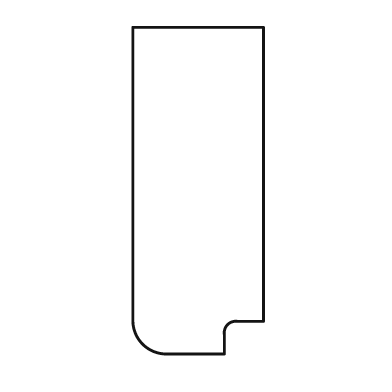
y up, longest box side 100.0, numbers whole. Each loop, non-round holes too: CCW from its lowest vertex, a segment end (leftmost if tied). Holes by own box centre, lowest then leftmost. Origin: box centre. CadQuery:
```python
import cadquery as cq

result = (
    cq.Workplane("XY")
    .moveTo(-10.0, -50.0)
    .lineTo(8.0, -50.0)
    .lineTo(8.0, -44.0)
    .threePointArc((9.0, -41.0), (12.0, -40.0))
    .lineTo(20.0, -40.0)
    .lineTo(20.0, 50.0)
    .lineTo(-20.0, 50.0)
    .lineTo(-20.0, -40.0)
    .threePointArc((-17.0, -47.0), (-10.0, -50.0))
    .close()
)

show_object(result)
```